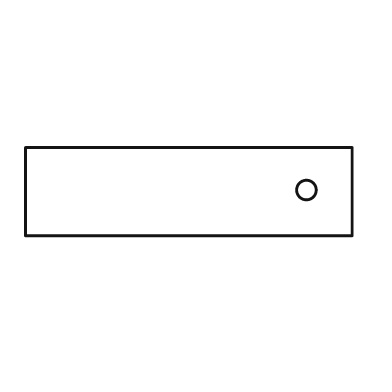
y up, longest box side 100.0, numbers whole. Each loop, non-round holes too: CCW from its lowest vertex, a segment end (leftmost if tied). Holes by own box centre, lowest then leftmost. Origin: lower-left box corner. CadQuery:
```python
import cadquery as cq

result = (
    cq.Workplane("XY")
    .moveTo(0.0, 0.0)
    .lineTo(100.0, 0.0)
    .lineTo(100.0, 27.0)
    .lineTo(0.0, 27.0)
    .close()
    .moveTo(86.0, 14.0)
    .circle(3.0)
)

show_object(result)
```